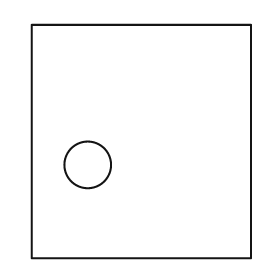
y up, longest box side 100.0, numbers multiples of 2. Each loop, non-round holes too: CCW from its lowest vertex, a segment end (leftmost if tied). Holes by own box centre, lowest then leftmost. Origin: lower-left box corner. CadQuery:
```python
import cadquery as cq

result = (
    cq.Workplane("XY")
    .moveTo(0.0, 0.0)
    .lineTo(94.0, 0.0)
    .lineTo(94.0, 100.0)
    .lineTo(0.0, 100.0)
    .close()
    .moveTo(24.0, 40.0)
    .circle(10.0)
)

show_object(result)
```